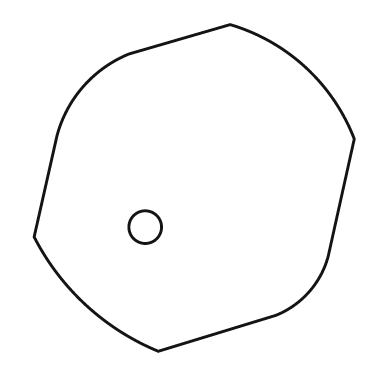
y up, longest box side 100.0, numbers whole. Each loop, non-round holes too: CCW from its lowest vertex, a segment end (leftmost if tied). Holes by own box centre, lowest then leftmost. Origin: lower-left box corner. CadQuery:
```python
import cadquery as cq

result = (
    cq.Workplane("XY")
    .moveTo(38.0, 0.0)
    .lineTo(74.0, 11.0)
    .threePointArc((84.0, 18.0), (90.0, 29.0))
    .lineTo(98.0, 65.0)
    .threePointArc((83.0, 87.0), (60.0, 100.0))
    .lineTo(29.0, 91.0)
    .threePointArc((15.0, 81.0), (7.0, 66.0))
    .lineTo(0.0, 35.0)
    .threePointArc((16.0, 14.0), (38.0, 0.0))
    .close()
    .moveTo(34.0, 38.0)
    .circle(5.0)
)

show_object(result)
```